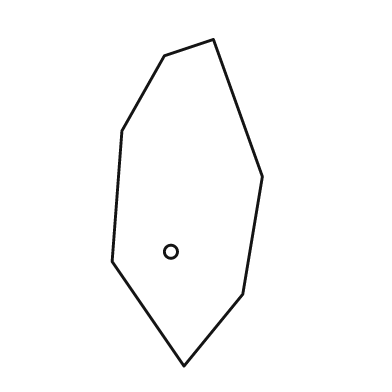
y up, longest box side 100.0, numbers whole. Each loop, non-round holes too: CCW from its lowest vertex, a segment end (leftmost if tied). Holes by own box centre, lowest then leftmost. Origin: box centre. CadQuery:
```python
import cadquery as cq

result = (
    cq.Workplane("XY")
    .moveTo(-1.0, -50.0)
    .lineTo(17.0, -28.0)
    .lineTo(23.0, 8.0)
    .lineTo(8.0, 50.0)
    .lineTo(-7.0, 45.0)
    .lineTo(-20.0, 22.0)
    .lineTo(-23.0, -18.0)
    .close()
    .moveTo(-5.0, -15.0)
    .circle(2.0)
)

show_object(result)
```